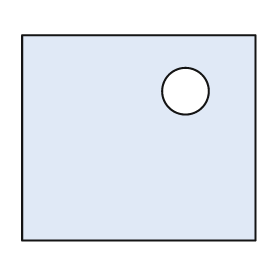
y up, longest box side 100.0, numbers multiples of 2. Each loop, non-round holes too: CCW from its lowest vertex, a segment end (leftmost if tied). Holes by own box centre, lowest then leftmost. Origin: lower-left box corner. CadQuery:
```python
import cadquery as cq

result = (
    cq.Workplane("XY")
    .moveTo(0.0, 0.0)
    .lineTo(100.0, 0.0)
    .lineTo(100.0, 88.0)
    .lineTo(0.0, 88.0)
    .close()
    .moveTo(70.0, 64.0)
    .circle(10.0)
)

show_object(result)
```